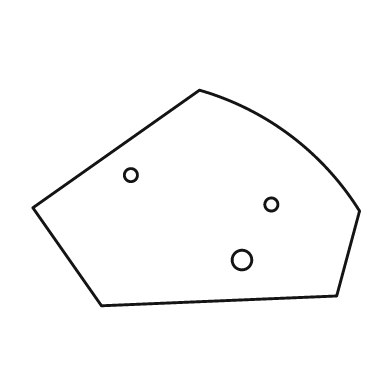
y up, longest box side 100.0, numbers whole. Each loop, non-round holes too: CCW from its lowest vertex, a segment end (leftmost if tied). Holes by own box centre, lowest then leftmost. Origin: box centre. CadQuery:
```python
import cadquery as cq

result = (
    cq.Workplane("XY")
    .moveTo(-29.0, -33.0)
    .lineTo(43.0, -30.0)
    .lineTo(50.0, -4.0)
    .threePointArc((29.0, 19.0), (1.0, 33.0))
    .lineTo(-50.0, -3.0)
    .close()
    .moveTo(14.0, -19.0)
    .circle(3.0)
    .moveTo(23.0, -2.0)
    .circle(2.0)
    .moveTo(-20.0, 7.0)
    .circle(2.0)
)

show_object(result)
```